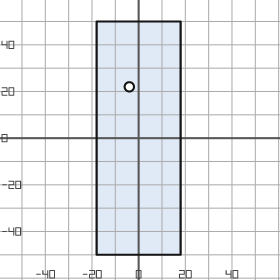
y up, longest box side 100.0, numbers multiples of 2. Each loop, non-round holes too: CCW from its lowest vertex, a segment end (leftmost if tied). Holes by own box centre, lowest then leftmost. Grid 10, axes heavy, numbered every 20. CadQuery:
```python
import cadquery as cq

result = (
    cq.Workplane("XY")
    .moveTo(-18.0, -50.0)
    .lineTo(18.0, -50.0)
    .lineTo(18.0, 50.0)
    .lineTo(-18.0, 50.0)
    .close()
    .moveTo(-4.0, 22.0)
    .circle(2.0)
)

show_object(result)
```